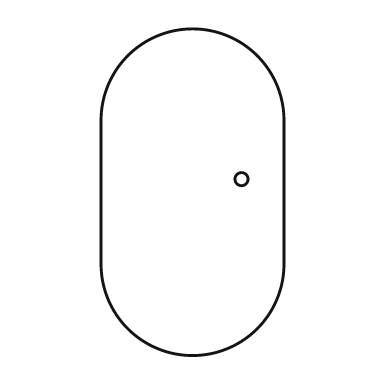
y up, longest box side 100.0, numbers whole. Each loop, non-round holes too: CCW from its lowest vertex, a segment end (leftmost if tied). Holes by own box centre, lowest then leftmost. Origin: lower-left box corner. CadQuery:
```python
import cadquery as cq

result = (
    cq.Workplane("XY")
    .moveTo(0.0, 28.0)
    .threePointArc((28.0, 0.0), (56.0, 28.0))
    .lineTo(56.0, 72.0)
    .threePointArc((28.0, 100.0), (0.0, 72.0))
    .close()
    .moveTo(43.0, 54.0)
    .circle(2.0)
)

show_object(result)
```